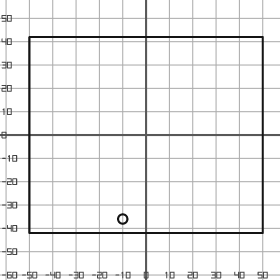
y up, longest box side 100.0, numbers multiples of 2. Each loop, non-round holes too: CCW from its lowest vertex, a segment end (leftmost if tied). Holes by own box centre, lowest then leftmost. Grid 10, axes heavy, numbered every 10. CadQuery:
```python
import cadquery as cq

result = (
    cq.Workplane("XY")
    .moveTo(-50.0, -42.0)
    .lineTo(50.0, -42.0)
    .lineTo(50.0, 42.0)
    .lineTo(-50.0, 42.0)
    .close()
    .moveTo(-10.0, -36.0)
    .circle(2.0)
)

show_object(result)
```